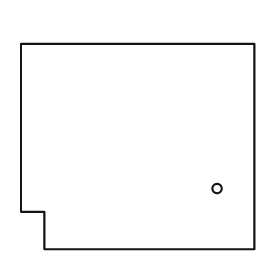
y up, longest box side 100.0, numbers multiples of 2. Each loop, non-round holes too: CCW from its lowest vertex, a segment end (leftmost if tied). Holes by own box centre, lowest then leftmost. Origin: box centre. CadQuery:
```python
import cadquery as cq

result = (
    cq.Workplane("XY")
    .moveTo(-40.0, -44.0)
    .lineTo(50.0, -44.0)
    .lineTo(50.0, 44.0)
    .lineTo(-50.0, 44.0)
    .lineTo(-50.0, -28.0)
    .lineTo(-40.0, -28.0)
    .close()
    .moveTo(34.0, -18.0)
    .circle(2.0)
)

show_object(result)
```